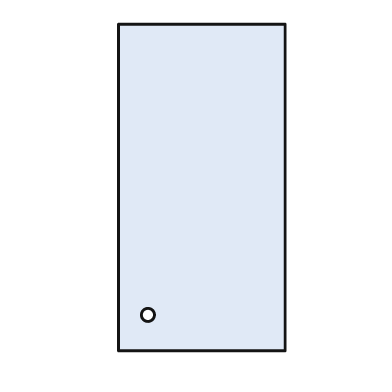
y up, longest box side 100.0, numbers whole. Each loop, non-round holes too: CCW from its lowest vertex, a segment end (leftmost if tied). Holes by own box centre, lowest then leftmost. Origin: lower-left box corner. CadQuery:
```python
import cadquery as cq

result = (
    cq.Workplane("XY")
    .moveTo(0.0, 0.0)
    .lineTo(51.0, 0.0)
    .lineTo(51.0, 100.0)
    .lineTo(0.0, 100.0)
    .close()
    .moveTo(9.0, 11.0)
    .circle(2.0)
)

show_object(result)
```